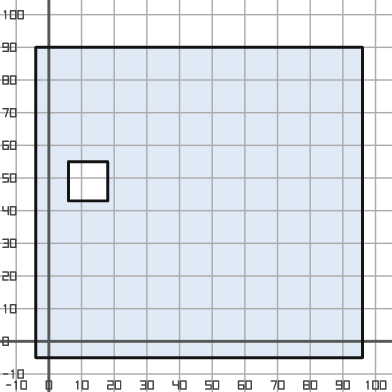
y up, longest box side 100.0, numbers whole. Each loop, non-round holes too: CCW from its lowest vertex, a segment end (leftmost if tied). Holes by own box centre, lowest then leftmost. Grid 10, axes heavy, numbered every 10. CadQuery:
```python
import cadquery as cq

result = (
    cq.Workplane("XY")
    .moveTo(-4.0, -5.0)
    .lineTo(96.0, -5.0)
    .lineTo(96.0, 90.0)
    .lineTo(-4.0, 90.0)
    .close()
    .moveTo(6.0, 43.0)
    .lineTo(18.0, 43.0)
    .lineTo(18.0, 55.0)
    .lineTo(6.0, 55.0)
    .close()
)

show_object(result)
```